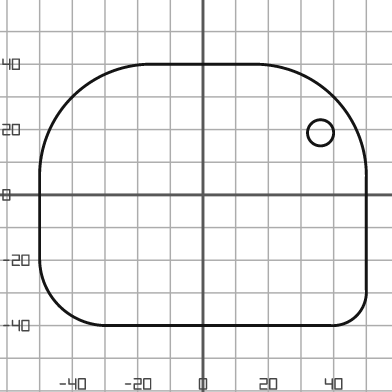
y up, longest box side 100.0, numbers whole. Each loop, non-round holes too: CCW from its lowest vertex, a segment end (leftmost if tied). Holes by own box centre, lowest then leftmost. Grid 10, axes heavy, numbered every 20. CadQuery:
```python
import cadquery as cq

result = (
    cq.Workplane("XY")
    .moveTo(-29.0, -40.0)
    .lineTo(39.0, -40.0)
    .threePointArc((47.0, -37.0), (50.0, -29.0))
    .lineTo(50.0, 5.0)
    .threePointArc((40.0, 30.0), (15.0, 40.0))
    .lineTo(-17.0, 40.0)
    .threePointArc((-40.0, 30.0), (-50.0, 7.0))
    .lineTo(-50.0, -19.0)
    .threePointArc((-44.0, -34.0), (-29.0, -40.0))
    .close()
    .moveTo(36.0, 19.0)
    .circle(4.0)
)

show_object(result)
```